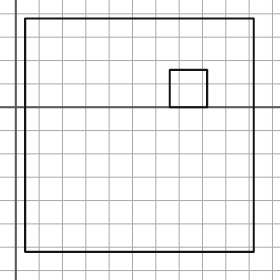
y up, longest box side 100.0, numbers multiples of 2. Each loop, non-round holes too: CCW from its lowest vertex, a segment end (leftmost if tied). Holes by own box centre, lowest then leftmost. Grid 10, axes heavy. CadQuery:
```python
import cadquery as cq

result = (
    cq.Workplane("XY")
    .moveTo(4.0, -62.0)
    .lineTo(102.0, -62.0)
    .lineTo(102.0, 38.0)
    .lineTo(4.0, 38.0)
    .close()
    .moveTo(66.0, 0.0)
    .lineTo(82.0, 0.0)
    .lineTo(82.0, 16.0)
    .lineTo(66.0, 16.0)
    .close()
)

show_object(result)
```